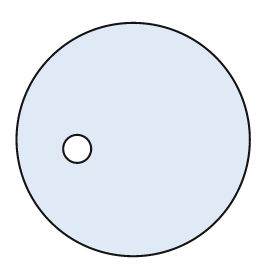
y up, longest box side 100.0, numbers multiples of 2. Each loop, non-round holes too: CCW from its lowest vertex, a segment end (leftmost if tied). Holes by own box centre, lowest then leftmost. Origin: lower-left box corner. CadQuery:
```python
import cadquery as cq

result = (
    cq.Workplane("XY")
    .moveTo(50.0, 50.0)
    .circle(50.0)
    .moveTo(26.0, 46.0)
    .circle(6.0)
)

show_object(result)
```